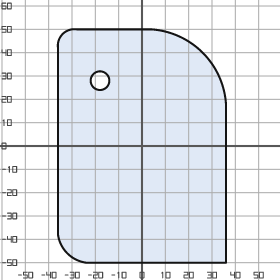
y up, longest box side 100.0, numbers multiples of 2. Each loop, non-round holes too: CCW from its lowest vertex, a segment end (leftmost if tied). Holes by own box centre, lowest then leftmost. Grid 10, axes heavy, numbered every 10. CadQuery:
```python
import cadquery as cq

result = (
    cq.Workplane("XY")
    .moveTo(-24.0, -50.0)
    .lineTo(36.0, -50.0)
    .lineTo(36.0, 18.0)
    .threePointArc((26.0, 40.0), (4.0, 50.0))
    .lineTo(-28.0, 50.0)
    .threePointArc((-34.0, 48.0), (-36.0, 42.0))
    .lineTo(-36.0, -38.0)
    .threePointArc((-32.0, -46.0), (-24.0, -50.0))
    .close()
    .moveTo(-18.0, 28.0)
    .circle(4.0)
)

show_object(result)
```